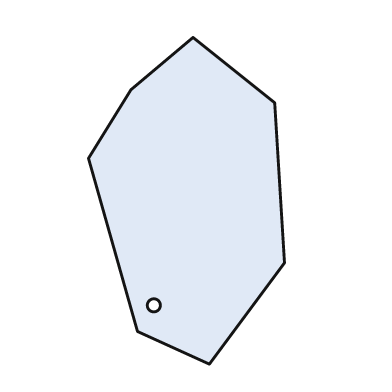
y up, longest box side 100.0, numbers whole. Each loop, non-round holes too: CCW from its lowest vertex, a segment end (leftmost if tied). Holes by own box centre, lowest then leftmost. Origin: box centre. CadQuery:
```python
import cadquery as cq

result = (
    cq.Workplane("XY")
    .moveTo(7.0, -50.0)
    .lineTo(30.0, -19.0)
    .lineTo(27.0, 30.0)
    .lineTo(2.0, 50.0)
    .lineTo(-17.0, 34.0)
    .lineTo(-30.0, 13.0)
    .lineTo(-15.0, -40.0)
    .close()
    .moveTo(-10.0, -32.0)
    .circle(2.0)
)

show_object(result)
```